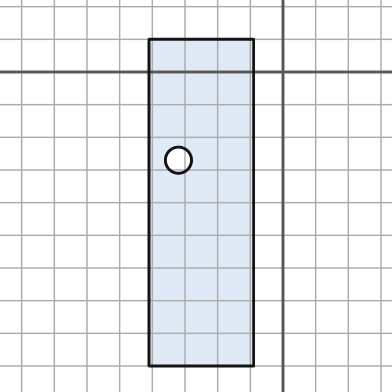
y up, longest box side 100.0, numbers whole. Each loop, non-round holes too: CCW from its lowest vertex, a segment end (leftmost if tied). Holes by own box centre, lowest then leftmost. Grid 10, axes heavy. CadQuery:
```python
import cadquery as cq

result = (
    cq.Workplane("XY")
    .moveTo(-41.0, -90.0)
    .lineTo(-9.0, -90.0)
    .lineTo(-9.0, 10.0)
    .lineTo(-41.0, 10.0)
    .close()
    .moveTo(-32.0, -27.0)
    .circle(4.0)
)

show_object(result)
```